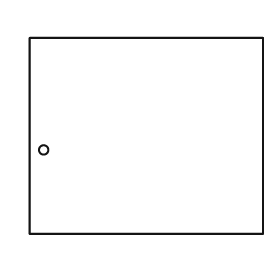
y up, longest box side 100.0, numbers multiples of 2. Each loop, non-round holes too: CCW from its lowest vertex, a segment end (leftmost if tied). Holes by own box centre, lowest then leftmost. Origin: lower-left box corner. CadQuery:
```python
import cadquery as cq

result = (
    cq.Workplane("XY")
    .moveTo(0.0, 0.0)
    .lineTo(100.0, 0.0)
    .lineTo(100.0, 84.0)
    .lineTo(0.0, 84.0)
    .close()
    .moveTo(6.0, 36.0)
    .circle(2.0)
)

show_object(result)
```